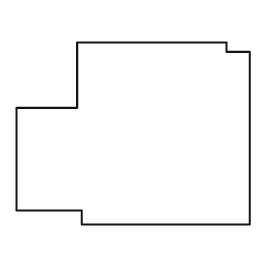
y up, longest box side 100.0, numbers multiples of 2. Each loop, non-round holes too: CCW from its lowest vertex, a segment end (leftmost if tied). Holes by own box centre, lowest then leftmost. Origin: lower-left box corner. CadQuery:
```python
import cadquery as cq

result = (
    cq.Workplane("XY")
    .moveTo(28.0, 0.0)
    .lineTo(100.0, 0.0)
    .lineTo(100.0, 74.0)
    .lineTo(90.0, 74.0)
    .lineTo(90.0, 78.0)
    .lineTo(26.0, 78.0)
    .lineTo(26.0, 50.0)
    .lineTo(0.0, 50.0)
    .lineTo(0.0, 6.0)
    .lineTo(28.0, 6.0)
    .close()
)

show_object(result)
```